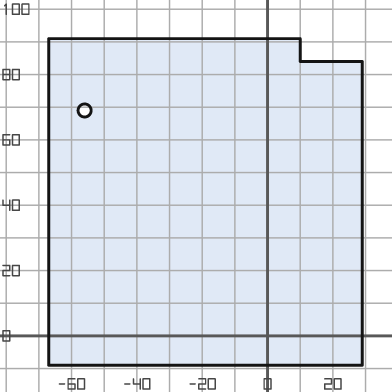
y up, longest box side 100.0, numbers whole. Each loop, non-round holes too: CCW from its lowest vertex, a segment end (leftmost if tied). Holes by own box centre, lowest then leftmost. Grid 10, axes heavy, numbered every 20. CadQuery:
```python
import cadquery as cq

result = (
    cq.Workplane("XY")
    .moveTo(-67.0, -9.0)
    .lineTo(29.0, -9.0)
    .lineTo(29.0, 84.0)
    .lineTo(10.0, 84.0)
    .lineTo(10.0, 91.0)
    .lineTo(-67.0, 91.0)
    .close()
    .moveTo(-56.0, 69.0)
    .circle(2.0)
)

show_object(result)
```